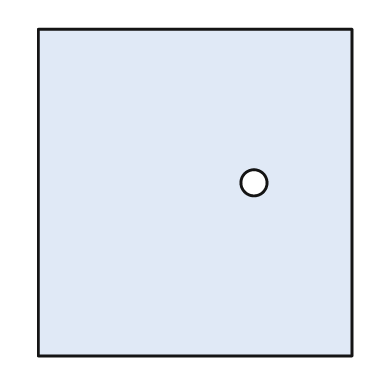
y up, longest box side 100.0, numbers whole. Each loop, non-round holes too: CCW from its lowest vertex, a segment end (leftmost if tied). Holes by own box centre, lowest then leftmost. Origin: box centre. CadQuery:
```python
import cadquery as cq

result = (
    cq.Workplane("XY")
    .moveTo(-48.0, -50.0)
    .lineTo(48.0, -50.0)
    .lineTo(48.0, 50.0)
    .lineTo(-48.0, 50.0)
    .close()
    .moveTo(18.0, 3.0)
    .circle(4.0)
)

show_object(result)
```